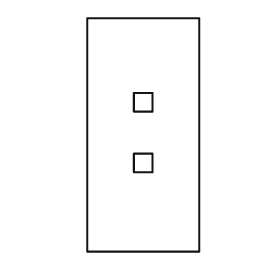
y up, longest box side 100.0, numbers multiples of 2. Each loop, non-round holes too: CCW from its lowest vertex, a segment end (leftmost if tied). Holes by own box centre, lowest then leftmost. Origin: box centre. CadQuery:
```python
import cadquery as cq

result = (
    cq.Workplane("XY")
    .moveTo(-24.0, -50.0)
    .lineTo(24.0, -50.0)
    .lineTo(24.0, 50.0)
    .lineTo(-24.0, 50.0)
    .close()
    .moveTo(-4.0, -16.0)
    .lineTo(4.0, -16.0)
    .lineTo(4.0, -8.0)
    .lineTo(-4.0, -8.0)
    .close()
    .moveTo(-4.0, 10.0)
    .lineTo(4.0, 10.0)
    .lineTo(4.0, 18.0)
    .lineTo(-4.0, 18.0)
    .close()
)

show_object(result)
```